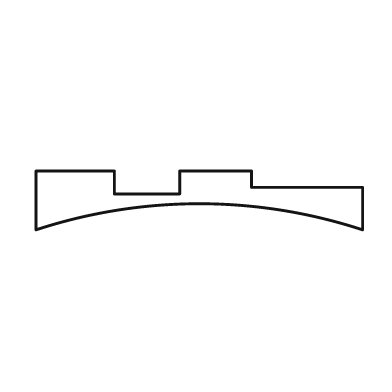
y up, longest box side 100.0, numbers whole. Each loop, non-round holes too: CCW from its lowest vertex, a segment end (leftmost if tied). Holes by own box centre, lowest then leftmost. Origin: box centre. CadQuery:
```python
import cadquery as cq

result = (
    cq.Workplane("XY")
    .moveTo(-50.0, -9.0)
    .threePointArc((0.0, -1.0), (50.0, -9.0))
    .lineTo(50.0, 4.0)
    .lineTo(16.0, 4.0)
    .lineTo(16.0, 9.0)
    .lineTo(-6.0, 9.0)
    .lineTo(-6.0, 2.0)
    .lineTo(-26.0, 2.0)
    .lineTo(-26.0, 9.0)
    .lineTo(-50.0, 9.0)
    .close()
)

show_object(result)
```